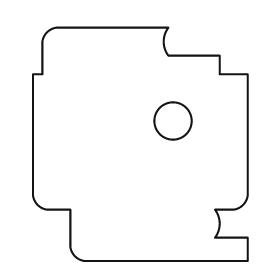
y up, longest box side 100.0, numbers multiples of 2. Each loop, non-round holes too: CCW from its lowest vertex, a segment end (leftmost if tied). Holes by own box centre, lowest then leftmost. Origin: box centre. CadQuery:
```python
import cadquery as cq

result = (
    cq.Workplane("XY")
    .moveTo(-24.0, -50.0)
    .lineTo(46.0, -50.0)
    .lineTo(46.0, -40.0)
    .lineTo(32.0, -40.0)
    .threePointArc((34.0, -34.0), (32.0, -28.0))
    .lineTo(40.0, -28.0)
    .threePointArc((44.0, -26.0), (46.0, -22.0))
    .lineTo(46.0, 30.0)
    .lineTo(34.0, 30.0)
    .lineTo(34.0, 38.0)
    .lineTo(12.0, 38.0)
    .threePointArc((10.0, 44.0), (12.0, 50.0))
    .lineTo(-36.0, 50.0)
    .threePointArc((-40.0, 48.0), (-42.0, 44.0))
    .lineTo(-42.0, 30.0)
    .lineTo(-46.0, 30.0)
    .lineTo(-46.0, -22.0)
    .threePointArc((-44.0, -26.0), (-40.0, -28.0))
    .lineTo(-30.0, -28.0)
    .lineTo(-30.0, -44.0)
    .threePointArc((-28.0, -48.0), (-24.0, -50.0))
    .close()
    .moveTo(14.0, 10.0)
    .circle(8.0)
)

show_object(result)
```